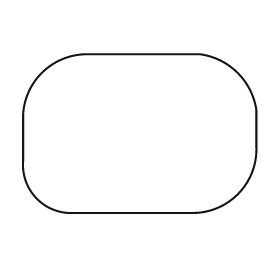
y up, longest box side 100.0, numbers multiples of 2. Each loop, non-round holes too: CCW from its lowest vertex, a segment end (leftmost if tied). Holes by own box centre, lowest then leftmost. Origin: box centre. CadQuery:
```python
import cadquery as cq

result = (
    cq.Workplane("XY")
    .moveTo(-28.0, -34.0)
    .lineTo(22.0, -34.0)
    .threePointArc((42.0, -26.0), (50.0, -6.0))
    .lineTo(50.0, 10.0)
    .threePointArc((42.0, 26.0), (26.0, 34.0))
    .lineTo(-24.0, 34.0)
    .threePointArc((-42.0, 26.0), (-50.0, 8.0))
    .lineTo(-50.0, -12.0)
    .threePointArc((-44.0, -28.0), (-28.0, -34.0))
    .close()
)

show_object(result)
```